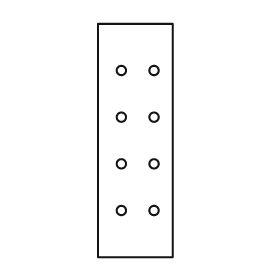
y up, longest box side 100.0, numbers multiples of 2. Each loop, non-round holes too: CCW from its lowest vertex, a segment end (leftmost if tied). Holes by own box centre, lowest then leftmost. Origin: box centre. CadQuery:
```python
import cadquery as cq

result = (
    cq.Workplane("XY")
    .moveTo(-16.0, -50.0)
    .lineTo(16.0, -50.0)
    .lineTo(16.0, 50.0)
    .lineTo(-16.0, 50.0)
    .close()
    .moveTo(-6.0, -30.0)
    .circle(2.0)
    .moveTo(8.0, -30.0)
    .circle(2.0)
    .moveTo(-6.0, -10.0)
    .circle(2.0)
    .moveTo(8.0, -10.0)
    .circle(2.0)
    .moveTo(-6.0, 10.0)
    .circle(2.0)
    .moveTo(8.0, 10.0)
    .circle(2.0)
    .moveTo(-6.0, 30.0)
    .circle(2.0)
    .moveTo(8.0, 30.0)
    .circle(2.0)
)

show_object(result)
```